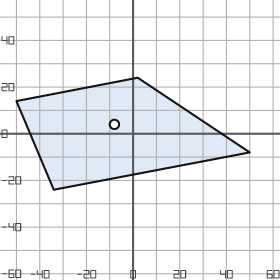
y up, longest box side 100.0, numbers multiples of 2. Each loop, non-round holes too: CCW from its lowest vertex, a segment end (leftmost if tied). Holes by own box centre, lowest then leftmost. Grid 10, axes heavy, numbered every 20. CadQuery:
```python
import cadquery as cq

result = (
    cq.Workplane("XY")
    .moveTo(-34.0, -24.0)
    .lineTo(50.0, -8.0)
    .lineTo(2.0, 24.0)
    .lineTo(-50.0, 14.0)
    .close()
    .moveTo(-8.0, 4.0)
    .circle(2.0)
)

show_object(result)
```